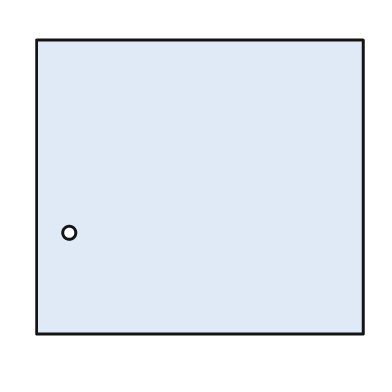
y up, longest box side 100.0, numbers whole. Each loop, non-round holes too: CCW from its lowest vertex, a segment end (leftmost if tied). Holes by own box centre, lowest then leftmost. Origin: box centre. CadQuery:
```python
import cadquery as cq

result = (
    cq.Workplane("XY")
    .moveTo(-50.0, -45.0)
    .lineTo(50.0, -45.0)
    .lineTo(50.0, 45.0)
    .lineTo(-50.0, 45.0)
    .close()
    .moveTo(-40.0, -14.0)
    .circle(2.0)
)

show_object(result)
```